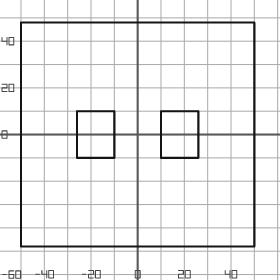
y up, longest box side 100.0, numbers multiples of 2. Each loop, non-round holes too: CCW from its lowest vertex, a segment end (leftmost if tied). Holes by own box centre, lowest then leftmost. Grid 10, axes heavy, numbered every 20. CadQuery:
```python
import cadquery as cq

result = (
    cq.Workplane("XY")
    .moveTo(-50.0, -48.0)
    .lineTo(50.0, -48.0)
    .lineTo(50.0, 48.0)
    .lineTo(-50.0, 48.0)
    .close()
    .moveTo(-26.0, -10.0)
    .lineTo(-10.0, -10.0)
    .lineTo(-10.0, 10.0)
    .lineTo(-26.0, 10.0)
    .close()
    .moveTo(10.0, -10.0)
    .lineTo(26.0, -10.0)
    .lineTo(26.0, 10.0)
    .lineTo(10.0, 10.0)
    .close()
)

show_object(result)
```